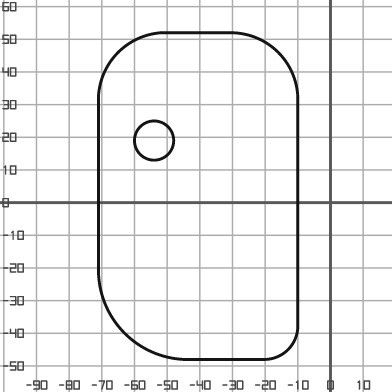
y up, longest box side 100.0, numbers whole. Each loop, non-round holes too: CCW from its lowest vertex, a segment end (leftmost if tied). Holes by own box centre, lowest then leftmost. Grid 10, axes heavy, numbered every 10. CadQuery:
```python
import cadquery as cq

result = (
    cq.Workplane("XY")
    .moveTo(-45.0, -48.0)
    .lineTo(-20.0, -48.0)
    .threePointArc((-13.0, -45.0), (-10.0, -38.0))
    .lineTo(-10.0, 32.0)
    .threePointArc((-16.0, 46.0), (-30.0, 52.0))
    .lineTo(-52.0, 52.0)
    .threePointArc((-65.0, 46.0), (-71.0, 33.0))
    .lineTo(-71.0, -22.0)
    .threePointArc((-63.0, -40.0), (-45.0, -48.0))
    .close()
    .moveTo(-54.0, 19.0)
    .circle(6.0)
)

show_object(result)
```